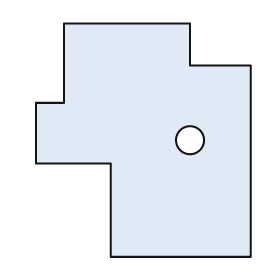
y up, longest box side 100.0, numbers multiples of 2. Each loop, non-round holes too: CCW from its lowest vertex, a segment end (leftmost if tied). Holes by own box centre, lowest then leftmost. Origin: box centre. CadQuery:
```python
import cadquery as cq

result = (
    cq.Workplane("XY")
    .moveTo(-14.0, -50.0)
    .lineTo(46.0, -50.0)
    .lineTo(46.0, 32.0)
    .lineTo(20.0, 32.0)
    .lineTo(20.0, 50.0)
    .lineTo(-34.0, 50.0)
    .lineTo(-34.0, 16.0)
    .lineTo(-46.0, 16.0)
    .lineTo(-46.0, -10.0)
    .lineTo(-14.0, -10.0)
    .close()
    .moveTo(20.0, 0.0)
    .circle(6.0)
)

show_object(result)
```